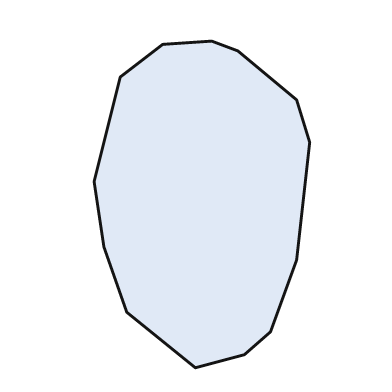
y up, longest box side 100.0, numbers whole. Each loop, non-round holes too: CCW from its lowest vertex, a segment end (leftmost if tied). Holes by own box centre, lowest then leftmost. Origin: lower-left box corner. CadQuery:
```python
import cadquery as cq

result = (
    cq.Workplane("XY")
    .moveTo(31.0, 0.0)
    .lineTo(46.0, 4.0)
    .lineTo(54.0, 11.0)
    .lineTo(62.0, 33.0)
    .lineTo(66.0, 69.0)
    .lineTo(62.0, 82.0)
    .lineTo(44.0, 97.0)
    .lineTo(36.0, 100.0)
    .lineTo(21.0, 99.0)
    .lineTo(8.0, 89.0)
    .lineTo(0.0, 57.0)
    .lineTo(3.0, 37.0)
    .lineTo(10.0, 17.0)
    .close()
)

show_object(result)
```